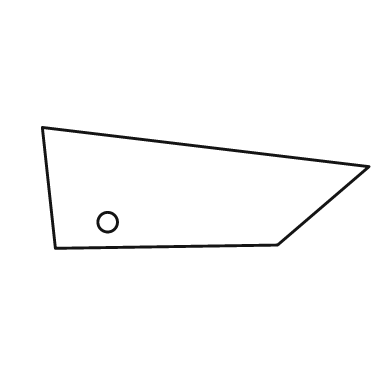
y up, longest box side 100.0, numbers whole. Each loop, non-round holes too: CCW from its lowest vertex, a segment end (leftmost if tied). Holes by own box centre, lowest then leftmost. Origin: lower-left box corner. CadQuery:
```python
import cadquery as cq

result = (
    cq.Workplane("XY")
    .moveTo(4.0, 0.0)
    .lineTo(72.0, 1.0)
    .lineTo(100.0, 25.0)
    .lineTo(0.0, 37.0)
    .close()
    .moveTo(20.0, 8.0)
    .circle(3.0)
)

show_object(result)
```